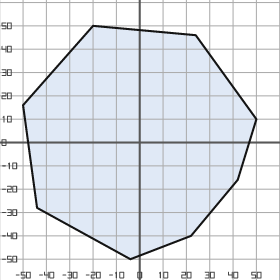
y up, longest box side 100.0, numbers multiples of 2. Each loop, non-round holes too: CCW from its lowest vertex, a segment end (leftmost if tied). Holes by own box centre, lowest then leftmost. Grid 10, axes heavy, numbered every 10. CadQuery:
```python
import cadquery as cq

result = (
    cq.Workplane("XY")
    .moveTo(-4.0, -50.0)
    .lineTo(22.0, -40.0)
    .lineTo(42.0, -16.0)
    .lineTo(50.0, 10.0)
    .lineTo(24.0, 46.0)
    .lineTo(-20.0, 50.0)
    .lineTo(-50.0, 16.0)
    .lineTo(-44.0, -28.0)
    .close()
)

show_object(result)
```